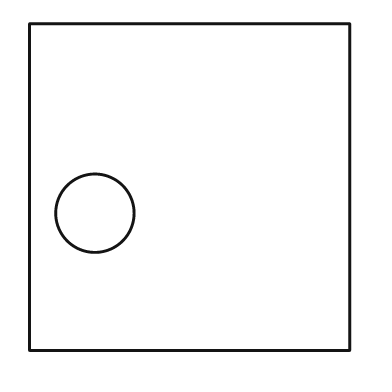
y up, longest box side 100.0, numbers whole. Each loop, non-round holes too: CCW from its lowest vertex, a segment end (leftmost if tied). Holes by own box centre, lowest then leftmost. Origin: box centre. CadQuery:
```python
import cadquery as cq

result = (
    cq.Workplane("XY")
    .moveTo(-49.0, -50.0)
    .lineTo(49.0, -50.0)
    .lineTo(49.0, 50.0)
    .lineTo(-49.0, 50.0)
    .close()
    .moveTo(-29.0, -8.0)
    .circle(12.0)
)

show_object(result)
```